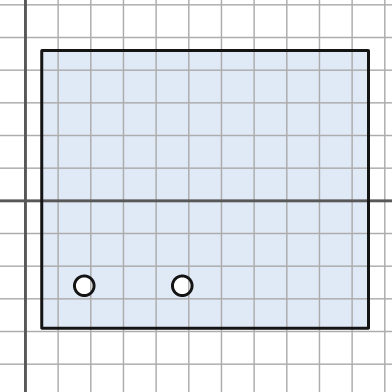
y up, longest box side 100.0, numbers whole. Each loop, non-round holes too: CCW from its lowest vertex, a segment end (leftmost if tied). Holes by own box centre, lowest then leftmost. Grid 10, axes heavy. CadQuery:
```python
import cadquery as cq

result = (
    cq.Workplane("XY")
    .moveTo(5.0, -39.0)
    .lineTo(105.0, -39.0)
    .lineTo(105.0, 46.0)
    .lineTo(5.0, 46.0)
    .close()
    .moveTo(18.0, -26.0)
    .circle(3.0)
    .moveTo(48.0, -26.0)
    .circle(3.0)
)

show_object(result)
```